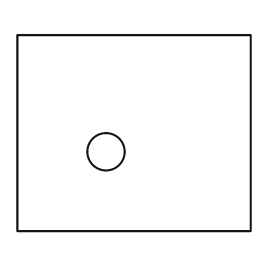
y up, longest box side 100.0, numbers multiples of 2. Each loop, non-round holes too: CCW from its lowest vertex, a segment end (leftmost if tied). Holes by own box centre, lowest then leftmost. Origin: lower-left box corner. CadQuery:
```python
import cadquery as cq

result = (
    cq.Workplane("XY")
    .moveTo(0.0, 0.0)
    .lineTo(100.0, 0.0)
    .lineTo(100.0, 84.0)
    .lineTo(0.0, 84.0)
    .close()
    .moveTo(38.0, 34.0)
    .circle(8.0)
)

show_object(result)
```